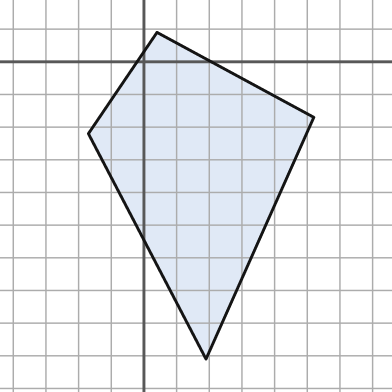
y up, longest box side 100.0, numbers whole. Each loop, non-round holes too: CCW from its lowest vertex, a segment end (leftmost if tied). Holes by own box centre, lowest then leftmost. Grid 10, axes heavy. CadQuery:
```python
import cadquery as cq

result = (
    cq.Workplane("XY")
    .moveTo(19.0, -91.0)
    .lineTo(52.0, -17.0)
    .lineTo(4.0, 9.0)
    .lineTo(-17.0, -22.0)
    .close()
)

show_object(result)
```